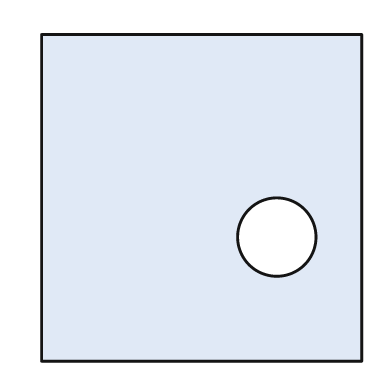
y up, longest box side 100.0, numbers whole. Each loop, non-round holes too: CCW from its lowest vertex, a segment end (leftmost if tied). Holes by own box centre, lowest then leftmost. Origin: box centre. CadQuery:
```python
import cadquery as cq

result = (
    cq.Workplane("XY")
    .moveTo(-49.0, -50.0)
    .lineTo(49.0, -50.0)
    .lineTo(49.0, 50.0)
    .lineTo(-49.0, 50.0)
    .close()
    .moveTo(23.0, -12.0)
    .circle(12.0)
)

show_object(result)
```